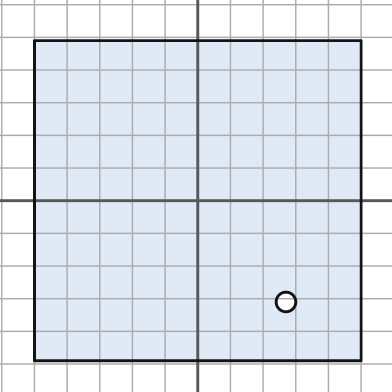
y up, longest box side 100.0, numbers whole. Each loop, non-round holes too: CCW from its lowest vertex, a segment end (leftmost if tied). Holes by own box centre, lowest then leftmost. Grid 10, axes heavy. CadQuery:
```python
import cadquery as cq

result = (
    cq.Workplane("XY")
    .moveTo(-50.0, -49.0)
    .lineTo(50.0, -49.0)
    .lineTo(50.0, 49.0)
    .lineTo(-50.0, 49.0)
    .close()
    .moveTo(27.0, -31.0)
    .circle(3.0)
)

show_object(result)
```